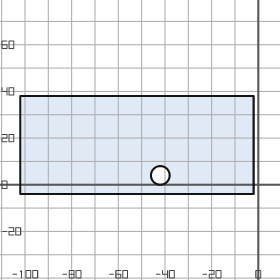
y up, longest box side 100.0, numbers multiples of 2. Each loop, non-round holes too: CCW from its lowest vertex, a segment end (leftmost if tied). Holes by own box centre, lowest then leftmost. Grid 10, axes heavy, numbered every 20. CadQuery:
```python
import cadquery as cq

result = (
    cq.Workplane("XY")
    .moveTo(-102.0, -4.0)
    .lineTo(-2.0, -4.0)
    .lineTo(-2.0, 38.0)
    .lineTo(-102.0, 38.0)
    .close()
    .moveTo(-42.0, 4.0)
    .circle(4.0)
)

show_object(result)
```